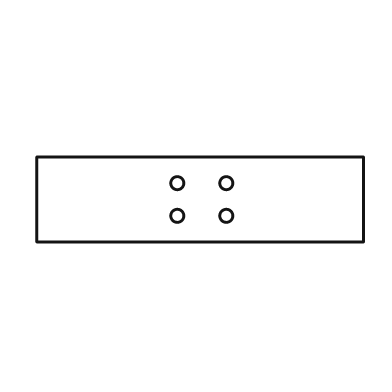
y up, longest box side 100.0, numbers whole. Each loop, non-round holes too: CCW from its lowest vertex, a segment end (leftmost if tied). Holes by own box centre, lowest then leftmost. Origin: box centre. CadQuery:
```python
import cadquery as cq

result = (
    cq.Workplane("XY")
    .moveTo(-50.0, -13.0)
    .lineTo(50.0, -13.0)
    .lineTo(50.0, 13.0)
    .lineTo(-50.0, 13.0)
    .close()
    .moveTo(-7.0, -5.0)
    .circle(2.0)
    .moveTo(8.0, -5.0)
    .circle(2.0)
    .moveTo(-7.0, 5.0)
    .circle(2.0)
    .moveTo(8.0, 5.0)
    .circle(2.0)
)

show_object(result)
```